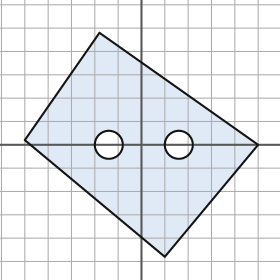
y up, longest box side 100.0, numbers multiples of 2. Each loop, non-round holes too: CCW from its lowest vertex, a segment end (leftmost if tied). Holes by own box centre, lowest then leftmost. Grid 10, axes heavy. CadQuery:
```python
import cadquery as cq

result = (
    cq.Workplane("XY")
    .moveTo(10.0, -48.0)
    .lineTo(50.0, 0.0)
    .lineTo(-18.0, 48.0)
    .lineTo(-50.0, 2.0)
    .close()
    .moveTo(-14.0, 0.0)
    .circle(6.0)
    .moveTo(16.0, 0.0)
    .circle(6.0)
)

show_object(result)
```